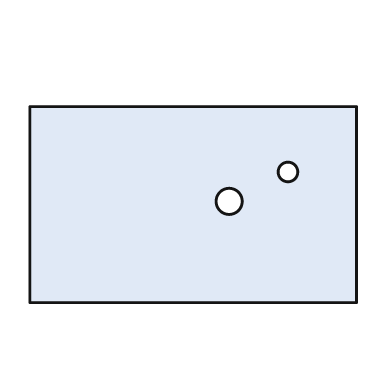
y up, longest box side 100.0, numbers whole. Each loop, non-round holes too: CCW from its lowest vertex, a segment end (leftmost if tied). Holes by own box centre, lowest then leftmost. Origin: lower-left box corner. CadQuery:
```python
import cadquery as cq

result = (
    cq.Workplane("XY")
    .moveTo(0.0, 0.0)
    .lineTo(100.0, 0.0)
    .lineTo(100.0, 60.0)
    .lineTo(0.0, 60.0)
    .close()
    .moveTo(61.0, 31.0)
    .circle(4.0)
    .moveTo(79.0, 40.0)
    .circle(3.0)
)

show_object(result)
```